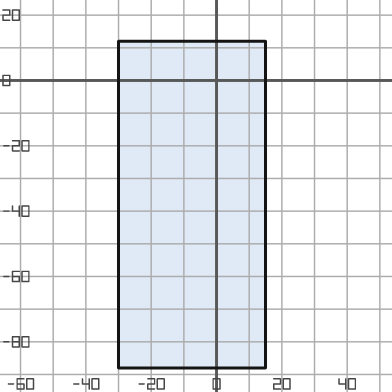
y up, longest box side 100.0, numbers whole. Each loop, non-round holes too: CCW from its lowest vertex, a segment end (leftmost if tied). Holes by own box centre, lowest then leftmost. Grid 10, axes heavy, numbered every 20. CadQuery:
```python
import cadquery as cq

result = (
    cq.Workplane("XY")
    .moveTo(-30.0, -88.0)
    .lineTo(15.0, -88.0)
    .lineTo(15.0, 12.0)
    .lineTo(-30.0, 12.0)
    .close()
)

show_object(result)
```